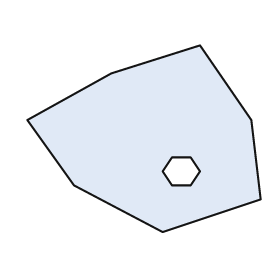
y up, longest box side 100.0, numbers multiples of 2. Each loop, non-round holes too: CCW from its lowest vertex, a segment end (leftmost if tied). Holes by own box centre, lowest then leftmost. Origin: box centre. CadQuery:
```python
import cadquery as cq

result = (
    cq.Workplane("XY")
    .moveTo(8.0, -40.0)
    .lineTo(50.0, -26.0)
    .lineTo(46.0, 8.0)
    .lineTo(24.0, 40.0)
    .lineTo(-14.0, 28.0)
    .lineTo(-50.0, 8.0)
    .lineTo(-30.0, -20.0)
    .close()
    .moveTo(12.0, -20.0)
    .lineTo(20.0, -20.0)
    .lineTo(24.0, -14.0)
    .lineTo(20.0, -8.0)
    .lineTo(12.0, -8.0)
    .lineTo(8.0, -14.0)
    .close()
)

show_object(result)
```